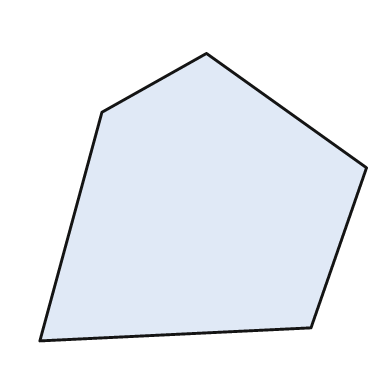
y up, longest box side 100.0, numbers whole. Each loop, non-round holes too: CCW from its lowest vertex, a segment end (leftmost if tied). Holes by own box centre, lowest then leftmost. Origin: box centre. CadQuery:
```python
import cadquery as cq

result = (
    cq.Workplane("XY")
    .moveTo(-50.0, -44.0)
    .lineTo(33.0, -40.0)
    .lineTo(50.0, 9.0)
    .lineTo(1.0, 44.0)
    .lineTo(-31.0, 26.0)
    .close()
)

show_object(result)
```